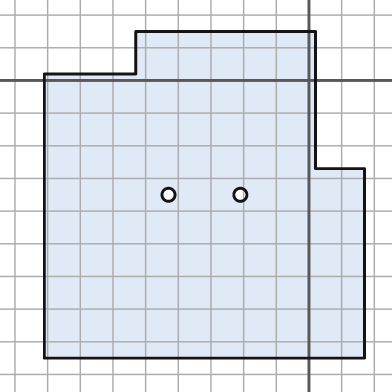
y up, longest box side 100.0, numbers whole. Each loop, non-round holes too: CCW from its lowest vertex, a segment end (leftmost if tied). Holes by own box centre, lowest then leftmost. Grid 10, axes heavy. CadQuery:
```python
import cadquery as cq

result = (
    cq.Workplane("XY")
    .moveTo(-81.0, -85.0)
    .lineTo(17.0, -85.0)
    .lineTo(17.0, -27.0)
    .lineTo(2.0, -27.0)
    .lineTo(2.0, 15.0)
    .lineTo(-53.0, 15.0)
    .lineTo(-53.0, 2.0)
    .lineTo(-81.0, 2.0)
    .close()
    .moveTo(-43.0, -35.0)
    .circle(2.0)
    .moveTo(-21.0, -35.0)
    .circle(2.0)
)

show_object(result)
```